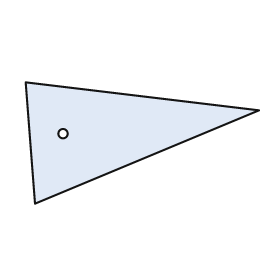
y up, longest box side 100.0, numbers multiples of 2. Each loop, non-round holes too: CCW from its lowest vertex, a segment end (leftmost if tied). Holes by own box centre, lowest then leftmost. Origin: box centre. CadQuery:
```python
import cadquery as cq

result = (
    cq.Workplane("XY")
    .moveTo(-46.0, -26.0)
    .lineTo(50.0, 14.0)
    .lineTo(-50.0, 26.0)
    .close()
    .moveTo(-34.0, 4.0)
    .circle(2.0)
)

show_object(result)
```